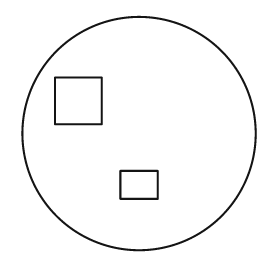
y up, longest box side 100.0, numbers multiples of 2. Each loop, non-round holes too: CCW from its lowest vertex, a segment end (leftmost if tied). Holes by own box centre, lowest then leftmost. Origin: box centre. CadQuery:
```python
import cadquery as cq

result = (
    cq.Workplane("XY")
    .moveTo(0.0, 0.0)
    .circle(50.0)
    .moveTo(-8.0, -28.0)
    .lineTo(8.0, -28.0)
    .lineTo(8.0, -16.0)
    .lineTo(-8.0, -16.0)
    .close()
    .moveTo(-36.0, 4.0)
    .lineTo(-16.0, 4.0)
    .lineTo(-16.0, 24.0)
    .lineTo(-36.0, 24.0)
    .close()
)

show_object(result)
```